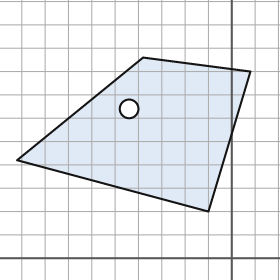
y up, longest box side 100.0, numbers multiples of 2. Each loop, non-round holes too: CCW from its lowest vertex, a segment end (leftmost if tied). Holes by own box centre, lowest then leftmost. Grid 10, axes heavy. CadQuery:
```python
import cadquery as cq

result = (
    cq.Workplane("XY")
    .moveTo(-10.0, 20.0)
    .lineTo(8.0, 80.0)
    .lineTo(-38.0, 86.0)
    .lineTo(-92.0, 42.0)
    .close()
    .moveTo(-44.0, 64.0)
    .circle(4.0)
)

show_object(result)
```